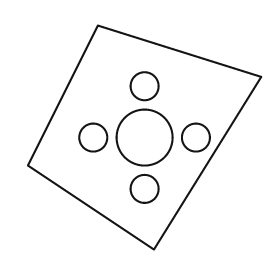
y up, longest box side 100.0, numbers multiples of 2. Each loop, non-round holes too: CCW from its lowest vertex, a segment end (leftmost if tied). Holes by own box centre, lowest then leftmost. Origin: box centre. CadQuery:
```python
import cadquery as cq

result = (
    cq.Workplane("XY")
    .moveTo(4.0, -48.0)
    .lineTo(50.0, 26.0)
    .lineTo(-20.0, 48.0)
    .lineTo(-50.0, -12.0)
    .close()
    .moveTo(0.0, -22.0)
    .circle(6.0)
    .moveTo(-22.0, 0.0)
    .circle(6.0)
    .moveTo(0.0, 0.0)
    .circle(12.0)
    .moveTo(22.0, 0.0)
    .circle(6.0)
    .moveTo(0.0, 22.0)
    .circle(6.0)
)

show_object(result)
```